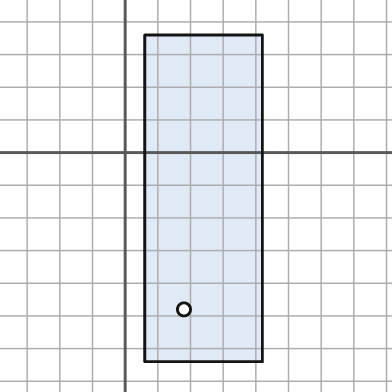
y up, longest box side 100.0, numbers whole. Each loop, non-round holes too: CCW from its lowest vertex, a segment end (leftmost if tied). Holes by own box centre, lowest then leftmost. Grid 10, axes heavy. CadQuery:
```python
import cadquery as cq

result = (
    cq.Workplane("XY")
    .moveTo(6.0, -64.0)
    .lineTo(42.0, -64.0)
    .lineTo(42.0, 36.0)
    .lineTo(6.0, 36.0)
    .close()
    .moveTo(18.0, -48.0)
    .circle(2.0)
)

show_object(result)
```